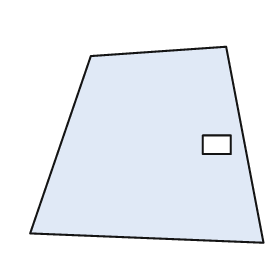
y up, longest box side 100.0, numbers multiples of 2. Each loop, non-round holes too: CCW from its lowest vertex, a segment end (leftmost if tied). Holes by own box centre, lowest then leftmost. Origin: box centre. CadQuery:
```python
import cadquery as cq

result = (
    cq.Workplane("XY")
    .moveTo(50.0, -42.0)
    .lineTo(34.0, 42.0)
    .lineTo(-24.0, 38.0)
    .lineTo(-50.0, -38.0)
    .close()
    .moveTo(24.0, -4.0)
    .lineTo(36.0, -4.0)
    .lineTo(36.0, 4.0)
    .lineTo(24.0, 4.0)
    .close()
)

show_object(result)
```